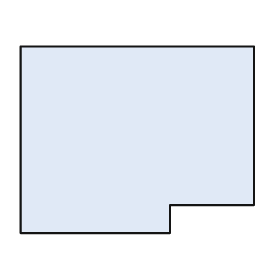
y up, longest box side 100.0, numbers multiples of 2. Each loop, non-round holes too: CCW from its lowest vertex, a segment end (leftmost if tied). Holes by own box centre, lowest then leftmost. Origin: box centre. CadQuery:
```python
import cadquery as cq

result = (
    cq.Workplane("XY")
    .moveTo(-50.0, -40.0)
    .lineTo(14.0, -40.0)
    .lineTo(14.0, -28.0)
    .lineTo(50.0, -28.0)
    .lineTo(50.0, 40.0)
    .lineTo(-50.0, 40.0)
    .close()
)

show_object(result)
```